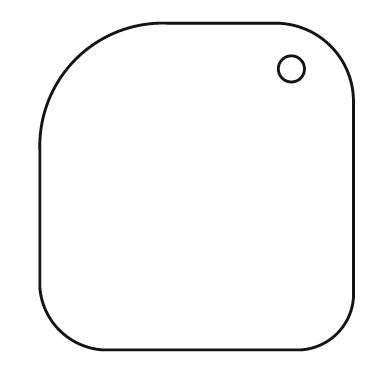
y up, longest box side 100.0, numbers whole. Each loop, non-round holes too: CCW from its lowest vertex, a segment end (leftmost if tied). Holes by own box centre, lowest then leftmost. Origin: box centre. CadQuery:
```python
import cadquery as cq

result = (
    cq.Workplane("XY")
    .moveTo(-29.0, -50.0)
    .lineTo(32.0, -50.0)
    .threePointArc((43.0, -45.0), (48.0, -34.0))
    .lineTo(48.0, 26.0)
    .threePointArc((41.0, 43.0), (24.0, 50.0))
    .lineTo(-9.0, 50.0)
    .threePointArc((-37.0, 39.0), (-48.0, 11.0))
    .lineTo(-48.0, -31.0)
    .threePointArc((-42.0, -44.0), (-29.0, -50.0))
    .close()
    .moveTo(29.0, 36.0)
    .circle(4.0)
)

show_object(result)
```